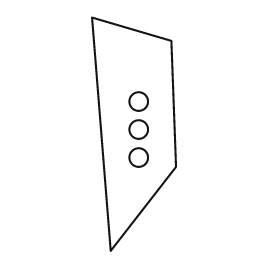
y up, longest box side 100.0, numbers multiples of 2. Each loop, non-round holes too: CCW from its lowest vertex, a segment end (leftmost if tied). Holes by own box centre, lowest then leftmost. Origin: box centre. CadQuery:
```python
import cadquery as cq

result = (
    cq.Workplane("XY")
    .moveTo(-10.0, -50.0)
    .lineTo(18.0, -14.0)
    .lineTo(16.0, 40.0)
    .lineTo(-18.0, 50.0)
    .close()
    .moveTo(2.0, -10.0)
    .circle(4.0)
    .moveTo(2.0, 2.0)
    .circle(4.0)
    .moveTo(2.0, 14.0)
    .circle(4.0)
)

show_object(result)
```